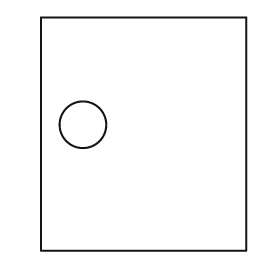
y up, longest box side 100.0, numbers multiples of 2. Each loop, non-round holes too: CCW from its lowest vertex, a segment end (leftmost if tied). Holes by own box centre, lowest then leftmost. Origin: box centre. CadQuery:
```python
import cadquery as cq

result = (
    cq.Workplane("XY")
    .moveTo(-44.0, -50.0)
    .lineTo(44.0, -50.0)
    .lineTo(44.0, 50.0)
    .lineTo(-44.0, 50.0)
    .close()
    .moveTo(-26.0, 4.0)
    .circle(10.0)
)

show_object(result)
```